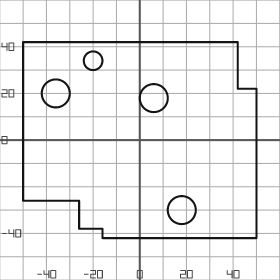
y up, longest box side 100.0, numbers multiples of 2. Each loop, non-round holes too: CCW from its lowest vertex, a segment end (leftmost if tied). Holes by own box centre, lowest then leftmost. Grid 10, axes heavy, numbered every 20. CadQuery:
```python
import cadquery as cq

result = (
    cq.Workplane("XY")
    .moveTo(-16.0, -42.0)
    .lineTo(50.0, -42.0)
    .lineTo(50.0, 22.0)
    .lineTo(42.0, 22.0)
    .lineTo(42.0, 42.0)
    .lineTo(-50.0, 42.0)
    .lineTo(-50.0, -26.0)
    .lineTo(-26.0, -26.0)
    .lineTo(-26.0, -38.0)
    .lineTo(-16.0, -38.0)
    .close()
    .moveTo(18.0, -30.0)
    .circle(6.0)
    .moveTo(6.0, 18.0)
    .circle(6.0)
    .moveTo(-36.0, 20.0)
    .circle(6.0)
    .moveTo(-20.0, 34.0)
    .circle(4.0)
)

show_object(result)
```